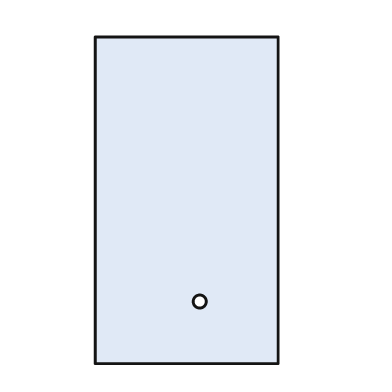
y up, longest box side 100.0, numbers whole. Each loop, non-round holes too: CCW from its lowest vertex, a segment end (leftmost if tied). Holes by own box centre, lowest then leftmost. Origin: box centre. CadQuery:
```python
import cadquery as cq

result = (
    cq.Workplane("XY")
    .moveTo(-28.0, -50.0)
    .lineTo(28.0, -50.0)
    .lineTo(28.0, 50.0)
    .lineTo(-28.0, 50.0)
    .close()
    .moveTo(4.0, -31.0)
    .circle(2.0)
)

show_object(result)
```